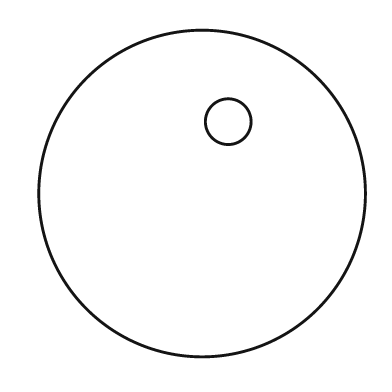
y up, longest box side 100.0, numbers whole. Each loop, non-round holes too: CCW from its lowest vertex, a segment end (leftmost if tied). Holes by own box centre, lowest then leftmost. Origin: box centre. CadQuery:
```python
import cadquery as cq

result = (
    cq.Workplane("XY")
    .moveTo(0.0, 0.0)
    .circle(50.0)
    .moveTo(8.0, 22.0)
    .circle(7.0)
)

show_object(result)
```